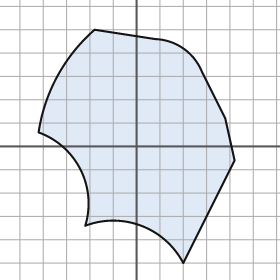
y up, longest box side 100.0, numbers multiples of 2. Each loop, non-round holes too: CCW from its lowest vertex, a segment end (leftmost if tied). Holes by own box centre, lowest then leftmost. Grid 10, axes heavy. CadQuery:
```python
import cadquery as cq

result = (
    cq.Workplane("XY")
    .moveTo(20.0, -50.0)
    .lineTo(42.0, -6.0)
    .lineTo(38.0, 12.0)
    .lineTo(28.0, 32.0)
    .threePointArc((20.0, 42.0), (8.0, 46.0))
    .lineTo(-18.0, 50.0)
    .threePointArc((-34.0, 30.0), (-42.0, 6.0))
    .threePointArc((-24.0, -10.0), (-22.0, -34.0))
    .threePointArc((2.0, -34.0), (20.0, -50.0))
    .close()
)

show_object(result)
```